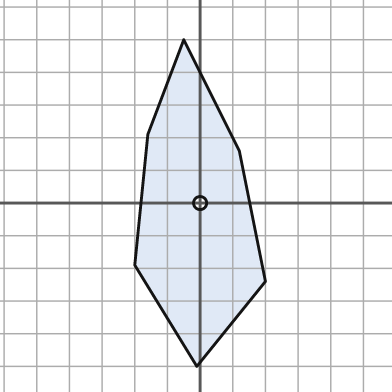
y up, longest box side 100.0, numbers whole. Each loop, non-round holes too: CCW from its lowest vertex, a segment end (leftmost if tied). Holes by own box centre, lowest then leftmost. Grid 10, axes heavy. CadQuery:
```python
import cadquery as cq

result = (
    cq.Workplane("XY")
    .moveTo(-1.0, -50.0)
    .lineTo(20.0, -24.0)
    .lineTo(12.0, 16.0)
    .lineTo(-5.0, 50.0)
    .lineTo(-16.0, 21.0)
    .lineTo(-20.0, -19.0)
    .close()
    .moveTo(0.0, 0.0)
    .circle(2.0)
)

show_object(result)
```